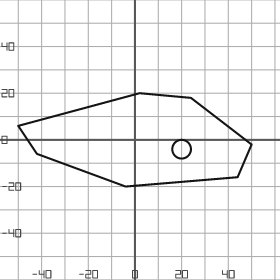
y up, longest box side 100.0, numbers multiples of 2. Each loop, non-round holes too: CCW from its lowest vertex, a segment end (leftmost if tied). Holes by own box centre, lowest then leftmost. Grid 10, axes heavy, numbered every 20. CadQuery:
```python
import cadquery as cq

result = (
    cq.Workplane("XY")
    .moveTo(-4.0, -20.0)
    .lineTo(44.0, -16.0)
    .lineTo(50.0, -2.0)
    .lineTo(24.0, 18.0)
    .lineTo(2.0, 20.0)
    .lineTo(-50.0, 6.0)
    .lineTo(-42.0, -6.0)
    .close()
    .moveTo(20.0, -4.0)
    .circle(4.0)
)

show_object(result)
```